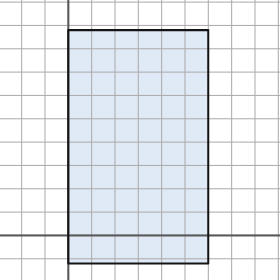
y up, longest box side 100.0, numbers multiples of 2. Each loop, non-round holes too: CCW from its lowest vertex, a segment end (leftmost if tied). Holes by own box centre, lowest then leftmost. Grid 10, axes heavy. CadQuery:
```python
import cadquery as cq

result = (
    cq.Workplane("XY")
    .moveTo(0.0, -12.0)
    .lineTo(60.0, -12.0)
    .lineTo(60.0, 88.0)
    .lineTo(0.0, 88.0)
    .close()
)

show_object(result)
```